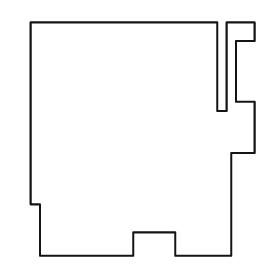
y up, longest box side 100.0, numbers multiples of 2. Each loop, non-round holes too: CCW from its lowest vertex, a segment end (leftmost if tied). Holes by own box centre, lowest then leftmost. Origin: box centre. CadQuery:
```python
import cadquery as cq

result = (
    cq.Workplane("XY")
    .moveTo(-44.0, -50.0)
    .lineTo(-4.0, -50.0)
    .lineTo(-4.0, -40.0)
    .lineTo(14.0, -40.0)
    .lineTo(14.0, -50.0)
    .lineTo(38.0, -50.0)
    .lineTo(38.0, -6.0)
    .lineTo(48.0, -6.0)
    .lineTo(48.0, 16.0)
    .lineTo(40.0, 16.0)
    .lineTo(40.0, 42.0)
    .lineTo(48.0, 42.0)
    .lineTo(48.0, 50.0)
    .lineTo(36.0, 50.0)
    .lineTo(36.0, 12.0)
    .lineTo(32.0, 12.0)
    .lineTo(32.0, 50.0)
    .lineTo(-48.0, 50.0)
    .lineTo(-48.0, -28.0)
    .lineTo(-44.0, -28.0)
    .close()
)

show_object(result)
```